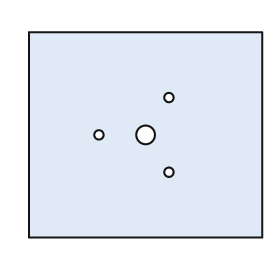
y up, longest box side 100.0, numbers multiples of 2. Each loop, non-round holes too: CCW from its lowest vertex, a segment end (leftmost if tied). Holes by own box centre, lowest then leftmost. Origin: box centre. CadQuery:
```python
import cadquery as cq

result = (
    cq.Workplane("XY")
    .moveTo(-50.0, -44.0)
    .lineTo(50.0, -44.0)
    .lineTo(50.0, 44.0)
    .lineTo(-50.0, 44.0)
    .close()
    .moveTo(10.0, -16.0)
    .circle(2.0)
    .moveTo(-20.0, 0.0)
    .circle(2.0)
    .moveTo(0.0, 0.0)
    .circle(4.0)
    .moveTo(10.0, 16.0)
    .circle(2.0)
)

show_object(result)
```